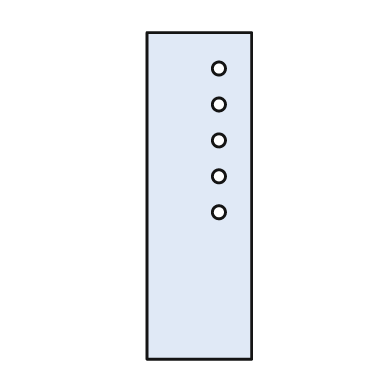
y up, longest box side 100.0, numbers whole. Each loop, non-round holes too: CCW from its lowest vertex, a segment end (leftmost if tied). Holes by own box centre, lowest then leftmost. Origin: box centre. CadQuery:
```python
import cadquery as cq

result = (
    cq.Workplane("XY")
    .moveTo(-16.0, -50.0)
    .lineTo(16.0, -50.0)
    .lineTo(16.0, 50.0)
    .lineTo(-16.0, 50.0)
    .close()
    .moveTo(6.0, -5.0)
    .circle(2.0)
    .moveTo(6.0, 6.0)
    .circle(2.0)
    .moveTo(6.0, 17.0)
    .circle(2.0)
    .moveTo(6.0, 28.0)
    .circle(2.0)
    .moveTo(6.0, 39.0)
    .circle(2.0)
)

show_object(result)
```